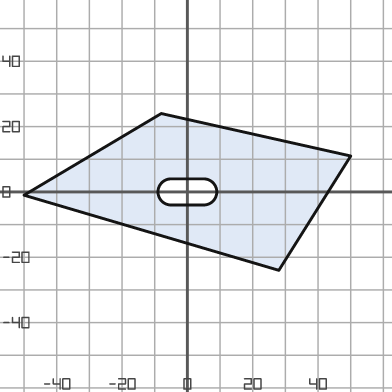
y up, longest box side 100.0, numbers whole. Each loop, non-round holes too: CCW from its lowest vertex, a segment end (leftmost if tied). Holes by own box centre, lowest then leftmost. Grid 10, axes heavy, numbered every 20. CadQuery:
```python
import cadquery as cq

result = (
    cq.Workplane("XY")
    .moveTo(28.0, -24.0)
    .lineTo(50.0, 11.0)
    .lineTo(-8.0, 24.0)
    .lineTo(-50.0, -1.0)
    .close()
    .moveTo(-5.0, -4.0)
    .lineTo(5.0, -4.0)
    .threePointArc((9.0, 0.0), (5.0, 4.0))
    .lineTo(-5.0, 4.0)
    .threePointArc((-9.0, 0.0), (-5.0, -4.0))
    .close()
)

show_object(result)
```